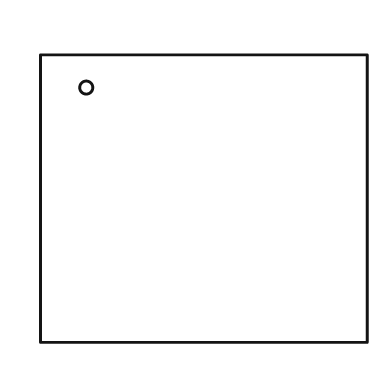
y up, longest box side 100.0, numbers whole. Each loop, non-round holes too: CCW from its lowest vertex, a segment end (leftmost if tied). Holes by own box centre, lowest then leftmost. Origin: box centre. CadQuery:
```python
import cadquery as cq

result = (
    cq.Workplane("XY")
    .moveTo(-50.0, -44.0)
    .lineTo(50.0, -44.0)
    .lineTo(50.0, 44.0)
    .lineTo(-50.0, 44.0)
    .close()
    .moveTo(-36.0, 34.0)
    .circle(2.0)
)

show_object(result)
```